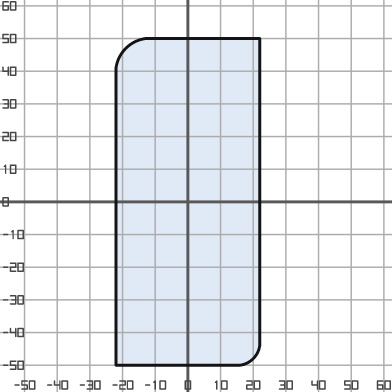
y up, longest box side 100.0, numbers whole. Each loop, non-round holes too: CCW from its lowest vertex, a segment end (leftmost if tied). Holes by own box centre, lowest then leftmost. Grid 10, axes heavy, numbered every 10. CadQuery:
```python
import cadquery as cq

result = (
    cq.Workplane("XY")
    .moveTo(-22.0, -50.0)
    .lineTo(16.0, -50.0)
    .threePointArc((20.0, -48.0), (22.0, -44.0))
    .lineTo(22.0, 50.0)
    .lineTo(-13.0, 50.0)
    .threePointArc((-19.0, 47.0), (-22.0, 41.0))
    .close()
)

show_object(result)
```